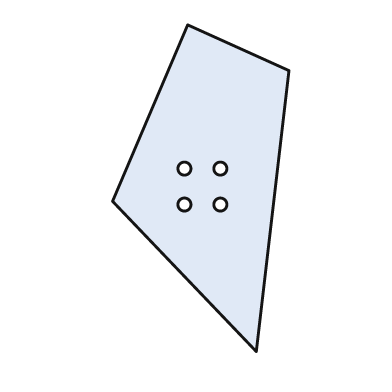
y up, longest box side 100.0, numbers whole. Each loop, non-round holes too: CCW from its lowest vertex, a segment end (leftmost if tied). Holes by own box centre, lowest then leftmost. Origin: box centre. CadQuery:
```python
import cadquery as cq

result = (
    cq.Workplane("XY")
    .moveTo(17.0, -50.0)
    .lineTo(27.0, 36.0)
    .lineTo(-4.0, 50.0)
    .lineTo(-27.0, -4.0)
    .close()
    .moveTo(-5.0, -5.0)
    .circle(2.0)
    .moveTo(6.0, -5.0)
    .circle(2.0)
    .moveTo(-5.0, 6.0)
    .circle(2.0)
    .moveTo(6.0, 6.0)
    .circle(2.0)
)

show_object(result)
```